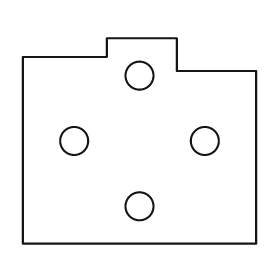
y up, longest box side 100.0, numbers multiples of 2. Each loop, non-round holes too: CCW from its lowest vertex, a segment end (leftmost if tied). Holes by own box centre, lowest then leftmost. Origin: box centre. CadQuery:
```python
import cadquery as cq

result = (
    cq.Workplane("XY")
    .moveTo(-50.0, -44.0)
    .lineTo(50.0, -44.0)
    .lineTo(50.0, 30.0)
    .lineTo(16.0, 30.0)
    .lineTo(16.0, 44.0)
    .lineTo(-14.0, 44.0)
    .lineTo(-14.0, 36.0)
    .lineTo(-50.0, 36.0)
    .close()
    .moveTo(0.0, -28.0)
    .circle(6.0)
    .moveTo(-28.0, 0.0)
    .circle(6.0)
    .moveTo(28.0, 0.0)
    .circle(6.0)
    .moveTo(0.0, 28.0)
    .circle(6.0)
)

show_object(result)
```